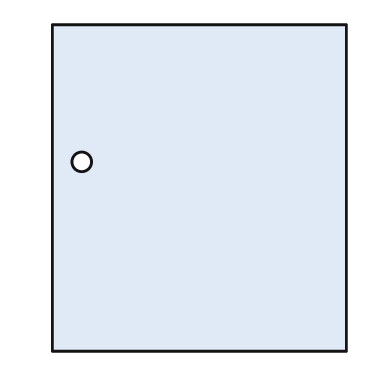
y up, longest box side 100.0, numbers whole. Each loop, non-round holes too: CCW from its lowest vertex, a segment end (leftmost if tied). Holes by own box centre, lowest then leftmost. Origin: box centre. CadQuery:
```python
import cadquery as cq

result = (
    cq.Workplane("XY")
    .moveTo(-45.0, -50.0)
    .lineTo(45.0, -50.0)
    .lineTo(45.0, 50.0)
    .lineTo(-45.0, 50.0)
    .close()
    .moveTo(-36.0, 8.0)
    .circle(3.0)
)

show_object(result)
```